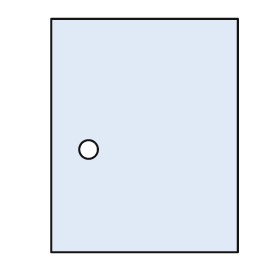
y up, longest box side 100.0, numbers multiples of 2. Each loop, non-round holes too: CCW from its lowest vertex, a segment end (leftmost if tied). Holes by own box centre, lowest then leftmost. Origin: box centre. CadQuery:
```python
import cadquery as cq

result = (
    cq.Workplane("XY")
    .moveTo(-40.0, -50.0)
    .lineTo(40.0, -50.0)
    .lineTo(40.0, 50.0)
    .lineTo(-40.0, 50.0)
    .close()
    .moveTo(-24.0, -6.0)
    .circle(4.0)
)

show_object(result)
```